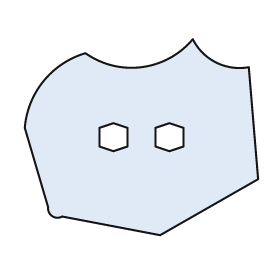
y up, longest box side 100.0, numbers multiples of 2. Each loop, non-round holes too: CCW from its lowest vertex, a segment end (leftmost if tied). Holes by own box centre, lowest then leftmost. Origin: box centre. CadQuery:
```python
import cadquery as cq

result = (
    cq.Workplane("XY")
    .moveTo(8.0, -42.0)
    .lineTo(50.0, -18.0)
    .lineTo(46.0, 30.0)
    .threePointArc((32.0, 32.0), (22.0, 42.0))
    .threePointArc((0.0, 30.0), (-24.0, 36.0))
    .threePointArc((-42.0, 24.0), (-50.0, 4.0))
    .lineTo(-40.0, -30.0)
    .threePointArc((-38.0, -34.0), (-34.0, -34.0))
    .close()
    .moveTo(-12.0, -6.0)
    .lineTo(-6.0, -4.0)
    .lineTo(-6.0, 4.0)
    .lineTo(-12.0, 6.0)
    .lineTo(-18.0, 4.0)
    .lineTo(-18.0, -4.0)
    .close()
    .moveTo(12.0, -6.0)
    .lineTo(18.0, -4.0)
    .lineTo(18.0, 4.0)
    .lineTo(12.0, 6.0)
    .lineTo(6.0, 4.0)
    .lineTo(6.0, -4.0)
    .close()
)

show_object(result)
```